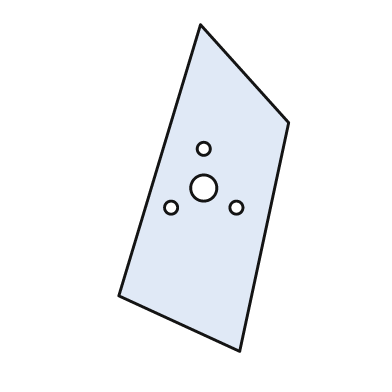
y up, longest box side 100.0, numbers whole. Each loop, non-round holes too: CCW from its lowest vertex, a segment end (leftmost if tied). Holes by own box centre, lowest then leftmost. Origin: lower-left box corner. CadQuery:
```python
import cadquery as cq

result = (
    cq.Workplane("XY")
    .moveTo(37.0, 0.0)
    .lineTo(52.0, 70.0)
    .lineTo(25.0, 100.0)
    .lineTo(0.0, 17.0)
    .close()
    .moveTo(16.0, 44.0)
    .circle(2.0)
    .moveTo(36.0, 44.0)
    .circle(2.0)
    .moveTo(26.0, 50.0)
    .circle(4.0)
    .moveTo(26.0, 62.0)
    .circle(2.0)
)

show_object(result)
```